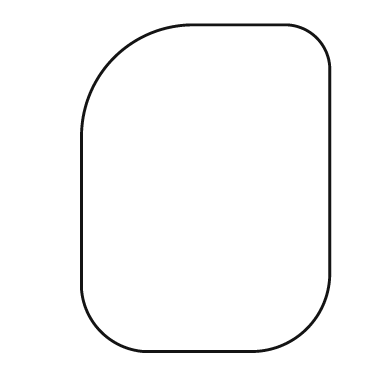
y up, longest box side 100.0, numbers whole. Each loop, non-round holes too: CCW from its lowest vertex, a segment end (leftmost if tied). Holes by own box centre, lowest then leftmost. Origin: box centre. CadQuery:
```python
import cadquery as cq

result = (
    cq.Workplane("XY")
    .moveTo(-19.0, -50.0)
    .lineTo(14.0, -50.0)
    .threePointArc((31.0, -43.0), (38.0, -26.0))
    .lineTo(38.0, 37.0)
    .threePointArc((34.0, 46.0), (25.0, 50.0))
    .lineTo(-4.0, 50.0)
    .threePointArc((-28.0, 40.0), (-38.0, 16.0))
    .lineTo(-38.0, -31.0)
    .threePointArc((-32.0, -44.0), (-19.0, -50.0))
    .close()
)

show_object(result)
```